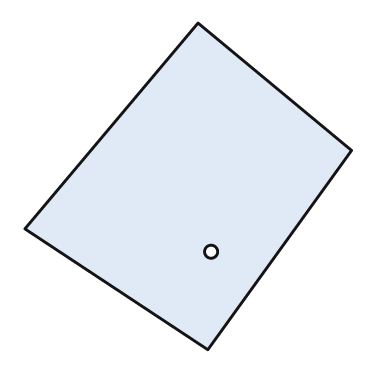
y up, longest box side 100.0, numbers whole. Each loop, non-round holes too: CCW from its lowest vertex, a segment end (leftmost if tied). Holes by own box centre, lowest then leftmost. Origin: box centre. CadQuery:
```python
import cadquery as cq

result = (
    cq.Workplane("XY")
    .moveTo(6.0, -50.0)
    .lineTo(50.0, 11.0)
    .lineTo(3.0, 50.0)
    .lineTo(-50.0, -13.0)
    .close()
    .moveTo(7.0, -20.0)
    .circle(2.0)
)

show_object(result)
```